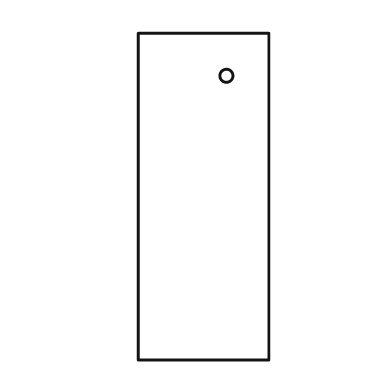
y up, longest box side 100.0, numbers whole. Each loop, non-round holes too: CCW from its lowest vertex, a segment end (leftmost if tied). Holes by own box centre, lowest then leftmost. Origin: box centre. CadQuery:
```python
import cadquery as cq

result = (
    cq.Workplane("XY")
    .moveTo(-20.0, -50.0)
    .lineTo(20.0, -50.0)
    .lineTo(20.0, 50.0)
    .lineTo(-20.0, 50.0)
    .close()
    .moveTo(7.0, 37.0)
    .circle(2.0)
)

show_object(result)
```